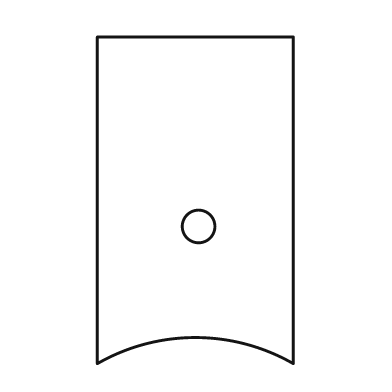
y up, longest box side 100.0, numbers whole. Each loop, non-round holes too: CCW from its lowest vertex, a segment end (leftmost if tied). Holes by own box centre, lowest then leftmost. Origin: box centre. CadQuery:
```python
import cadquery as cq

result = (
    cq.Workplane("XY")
    .moveTo(-30.0, -50.0)
    .threePointArc((0.0, -42.0), (30.0, -50.0))
    .lineTo(30.0, 50.0)
    .lineTo(-30.0, 50.0)
    .close()
    .moveTo(1.0, -8.0)
    .circle(5.0)
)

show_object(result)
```